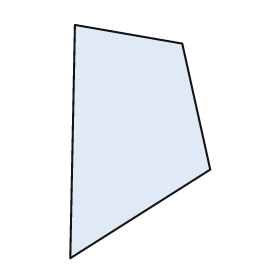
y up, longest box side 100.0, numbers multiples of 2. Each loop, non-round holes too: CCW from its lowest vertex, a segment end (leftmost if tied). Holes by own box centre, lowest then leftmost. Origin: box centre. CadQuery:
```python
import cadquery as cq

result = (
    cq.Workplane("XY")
    .moveTo(-30.0, -50.0)
    .lineTo(30.0, -12.0)
    .lineTo(18.0, 42.0)
    .lineTo(-28.0, 50.0)
    .close()
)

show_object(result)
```